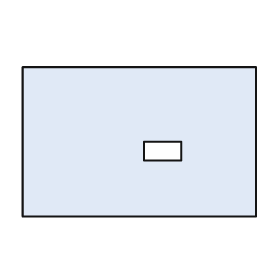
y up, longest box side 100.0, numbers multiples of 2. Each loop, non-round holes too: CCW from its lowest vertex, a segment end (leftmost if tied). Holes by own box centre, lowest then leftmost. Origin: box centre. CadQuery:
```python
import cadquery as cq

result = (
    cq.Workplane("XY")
    .moveTo(-50.0, -32.0)
    .lineTo(50.0, -32.0)
    .lineTo(50.0, 32.0)
    .lineTo(-50.0, 32.0)
    .close()
    .moveTo(2.0, -8.0)
    .lineTo(18.0, -8.0)
    .lineTo(18.0, 0.0)
    .lineTo(2.0, 0.0)
    .close()
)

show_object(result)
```